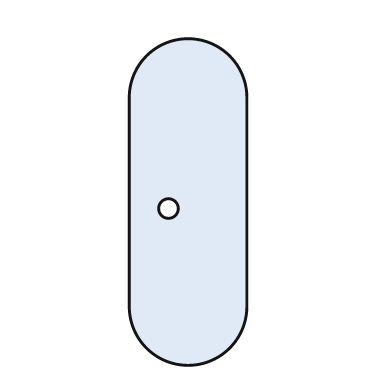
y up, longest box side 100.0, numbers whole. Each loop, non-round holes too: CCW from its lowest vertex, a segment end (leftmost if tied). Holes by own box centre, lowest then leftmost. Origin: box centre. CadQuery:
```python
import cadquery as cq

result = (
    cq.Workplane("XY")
    .moveTo(-18.0, -32.0)
    .threePointArc((0.0, -50.0), (18.0, -32.0))
    .lineTo(18.0, 32.0)
    .threePointArc((0.0, 50.0), (-18.0, 32.0))
    .close()
    .moveTo(-6.0, -2.0)
    .circle(3.0)
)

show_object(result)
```